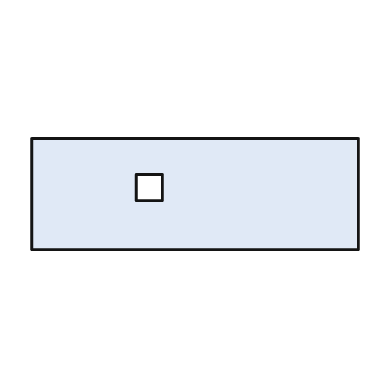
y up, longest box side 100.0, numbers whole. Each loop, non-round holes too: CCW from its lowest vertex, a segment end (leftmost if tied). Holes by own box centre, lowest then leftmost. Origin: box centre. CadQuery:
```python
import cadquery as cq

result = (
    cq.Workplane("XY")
    .moveTo(-50.0, -17.0)
    .lineTo(50.0, -17.0)
    .lineTo(50.0, 17.0)
    .lineTo(-50.0, 17.0)
    .close()
    .moveTo(-18.0, -2.0)
    .lineTo(-10.0, -2.0)
    .lineTo(-10.0, 6.0)
    .lineTo(-18.0, 6.0)
    .close()
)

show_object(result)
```